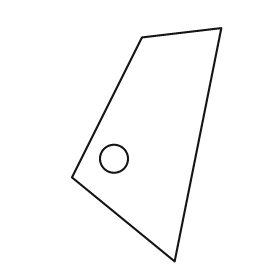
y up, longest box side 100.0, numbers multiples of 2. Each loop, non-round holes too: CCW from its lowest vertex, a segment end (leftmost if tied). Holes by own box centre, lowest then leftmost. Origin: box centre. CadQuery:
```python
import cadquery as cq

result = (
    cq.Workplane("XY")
    .moveTo(12.0, -50.0)
    .lineTo(32.0, 50.0)
    .lineTo(-2.0, 46.0)
    .lineTo(-32.0, -14.0)
    .close()
    .moveTo(-14.0, -6.0)
    .circle(6.0)
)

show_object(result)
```